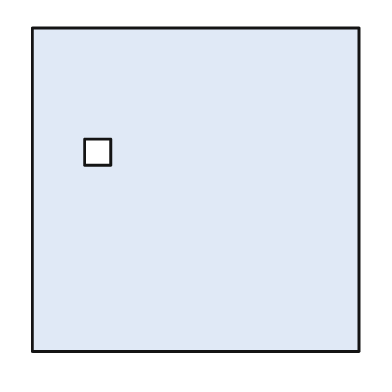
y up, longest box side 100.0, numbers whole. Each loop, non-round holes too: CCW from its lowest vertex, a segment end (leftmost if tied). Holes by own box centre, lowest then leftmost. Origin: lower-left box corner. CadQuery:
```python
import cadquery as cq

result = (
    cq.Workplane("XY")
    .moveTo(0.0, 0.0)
    .lineTo(100.0, 0.0)
    .lineTo(100.0, 99.0)
    .lineTo(0.0, 99.0)
    .close()
    .moveTo(16.0, 57.0)
    .lineTo(24.0, 57.0)
    .lineTo(24.0, 65.0)
    .lineTo(16.0, 65.0)
    .close()
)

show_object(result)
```